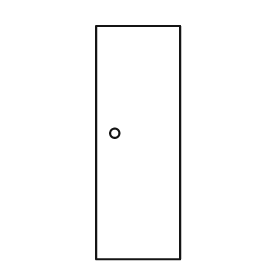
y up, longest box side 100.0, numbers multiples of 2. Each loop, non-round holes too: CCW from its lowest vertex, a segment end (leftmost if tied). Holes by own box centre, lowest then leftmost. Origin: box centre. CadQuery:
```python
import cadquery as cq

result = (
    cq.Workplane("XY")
    .moveTo(-18.0, -50.0)
    .lineTo(18.0, -50.0)
    .lineTo(18.0, 50.0)
    .lineTo(-18.0, 50.0)
    .close()
    .moveTo(-10.0, 4.0)
    .circle(2.0)
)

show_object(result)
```